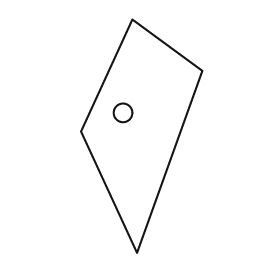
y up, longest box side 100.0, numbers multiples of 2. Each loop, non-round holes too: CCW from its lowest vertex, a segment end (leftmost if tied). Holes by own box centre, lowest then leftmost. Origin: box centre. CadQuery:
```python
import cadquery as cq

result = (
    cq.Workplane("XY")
    .moveTo(-2.0, -50.0)
    .lineTo(26.0, 28.0)
    .lineTo(-4.0, 50.0)
    .lineTo(-26.0, 2.0)
    .close()
    .moveTo(-8.0, 10.0)
    .circle(4.0)
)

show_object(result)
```